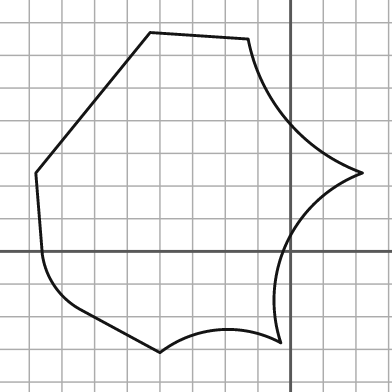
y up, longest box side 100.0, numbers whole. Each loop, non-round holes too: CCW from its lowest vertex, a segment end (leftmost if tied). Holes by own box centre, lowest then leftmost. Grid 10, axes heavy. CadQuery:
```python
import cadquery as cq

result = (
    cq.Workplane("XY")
    .moveTo(-40.0, -31.0)
    .threePointArc((-22.0, -24.0), (-3.0, -28.0))
    .threePointArc((-1.0, 3.0), (22.0, 24.0))
    .threePointArc((-1.0, 40.0), (-13.0, 65.0))
    .lineTo(-43.0, 67.0)
    .lineTo(-78.0, 24.0)
    .lineTo(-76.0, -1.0)
    .threePointArc((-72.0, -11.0), (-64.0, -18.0))
    .close()
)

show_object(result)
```